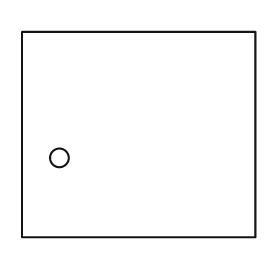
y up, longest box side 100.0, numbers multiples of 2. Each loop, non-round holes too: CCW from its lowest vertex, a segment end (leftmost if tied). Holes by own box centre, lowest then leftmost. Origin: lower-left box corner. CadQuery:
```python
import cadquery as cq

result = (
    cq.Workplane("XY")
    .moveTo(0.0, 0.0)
    .lineTo(100.0, 0.0)
    .lineTo(100.0, 88.0)
    .lineTo(0.0, 88.0)
    .close()
    .moveTo(16.0, 34.0)
    .circle(4.0)
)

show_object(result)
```